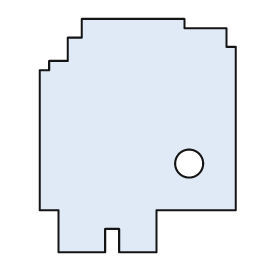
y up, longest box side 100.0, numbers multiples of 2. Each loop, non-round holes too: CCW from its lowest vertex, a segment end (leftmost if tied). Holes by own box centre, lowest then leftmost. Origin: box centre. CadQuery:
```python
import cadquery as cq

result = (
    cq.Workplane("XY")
    .moveTo(-34.0, -50.0)
    .lineTo(-14.0, -50.0)
    .lineTo(-14.0, -40.0)
    .lineTo(-8.0, -40.0)
    .lineTo(-8.0, -50.0)
    .lineTo(8.0, -50.0)
    .lineTo(8.0, -32.0)
    .lineTo(42.0, -32.0)
    .lineTo(42.0, 38.0)
    .lineTo(38.0, 38.0)
    .lineTo(38.0, 46.0)
    .lineTo(20.0, 46.0)
    .lineTo(20.0, 50.0)
    .lineTo(-24.0, 50.0)
    .lineTo(-24.0, 42.0)
    .lineTo(-30.0, 42.0)
    .lineTo(-30.0, 32.0)
    .lineTo(-38.0, 32.0)
    .lineTo(-38.0, 28.0)
    .lineTo(-42.0, 28.0)
    .lineTo(-42.0, -32.0)
    .lineTo(-34.0, -32.0)
    .close()
    .moveTo(22.0, -12.0)
    .circle(6.0)
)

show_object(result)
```